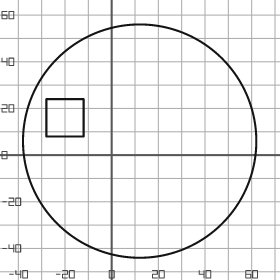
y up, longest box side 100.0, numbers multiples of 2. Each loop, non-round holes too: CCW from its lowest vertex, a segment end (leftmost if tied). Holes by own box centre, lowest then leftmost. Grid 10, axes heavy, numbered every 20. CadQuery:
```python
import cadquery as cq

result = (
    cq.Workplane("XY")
    .moveTo(12.0, 6.0)
    .circle(50.0)
    .moveTo(-28.0, 8.0)
    .lineTo(-12.0, 8.0)
    .lineTo(-12.0, 24.0)
    .lineTo(-28.0, 24.0)
    .close()
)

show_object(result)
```